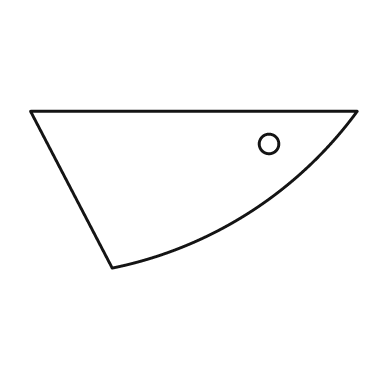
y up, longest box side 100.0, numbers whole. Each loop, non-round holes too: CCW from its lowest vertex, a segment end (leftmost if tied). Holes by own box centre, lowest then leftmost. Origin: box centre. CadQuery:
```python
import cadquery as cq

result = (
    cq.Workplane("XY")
    .moveTo(-25.0, -24.0)
    .threePointArc((17.0, -7.0), (50.0, 24.0))
    .lineTo(-50.0, 24.0)
    .close()
    .moveTo(23.0, 14.0)
    .circle(3.0)
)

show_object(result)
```